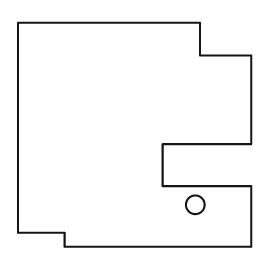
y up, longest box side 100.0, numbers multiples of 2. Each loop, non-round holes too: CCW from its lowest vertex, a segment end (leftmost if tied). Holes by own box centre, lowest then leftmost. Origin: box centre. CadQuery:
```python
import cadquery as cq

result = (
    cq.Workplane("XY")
    .moveTo(-30.0, -48.0)
    .lineTo(50.0, -48.0)
    .lineTo(50.0, -22.0)
    .lineTo(12.0, -22.0)
    .lineTo(12.0, -4.0)
    .lineTo(50.0, -4.0)
    .lineTo(50.0, 34.0)
    .lineTo(28.0, 34.0)
    .lineTo(28.0, 48.0)
    .lineTo(-50.0, 48.0)
    .lineTo(-50.0, -42.0)
    .lineTo(-30.0, -42.0)
    .close()
    .moveTo(26.0, -30.0)
    .circle(4.0)
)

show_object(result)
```